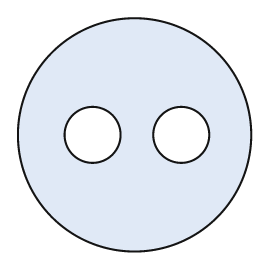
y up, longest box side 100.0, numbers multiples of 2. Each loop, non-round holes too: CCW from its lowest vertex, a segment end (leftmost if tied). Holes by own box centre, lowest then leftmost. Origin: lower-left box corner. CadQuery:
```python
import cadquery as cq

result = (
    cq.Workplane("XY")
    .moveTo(50.0, 50.0)
    .circle(50.0)
    .moveTo(32.0, 50.0)
    .circle(12.0)
    .moveTo(70.0, 50.0)
    .circle(12.0)
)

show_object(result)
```